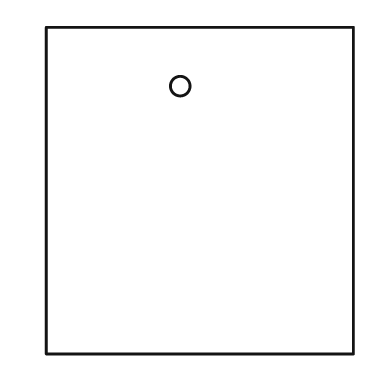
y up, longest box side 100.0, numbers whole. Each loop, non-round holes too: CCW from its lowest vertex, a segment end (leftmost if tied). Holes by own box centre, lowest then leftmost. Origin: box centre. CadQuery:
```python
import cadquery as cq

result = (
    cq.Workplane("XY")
    .moveTo(-47.0, -50.0)
    .lineTo(47.0, -50.0)
    .lineTo(47.0, 50.0)
    .lineTo(-47.0, 50.0)
    .close()
    .moveTo(-6.0, 32.0)
    .circle(3.0)
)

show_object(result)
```